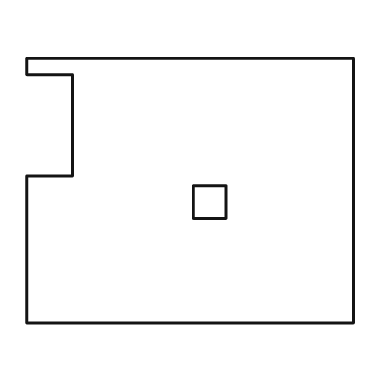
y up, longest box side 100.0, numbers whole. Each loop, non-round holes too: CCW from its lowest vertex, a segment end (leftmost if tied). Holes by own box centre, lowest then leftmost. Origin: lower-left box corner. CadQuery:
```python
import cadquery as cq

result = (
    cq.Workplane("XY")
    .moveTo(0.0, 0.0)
    .lineTo(100.0, 0.0)
    .lineTo(100.0, 81.0)
    .lineTo(0.0, 81.0)
    .lineTo(0.0, 76.0)
    .lineTo(14.0, 76.0)
    .lineTo(14.0, 45.0)
    .lineTo(0.0, 45.0)
    .close()
    .moveTo(51.0, 32.0)
    .lineTo(61.0, 32.0)
    .lineTo(61.0, 42.0)
    .lineTo(51.0, 42.0)
    .close()
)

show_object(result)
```